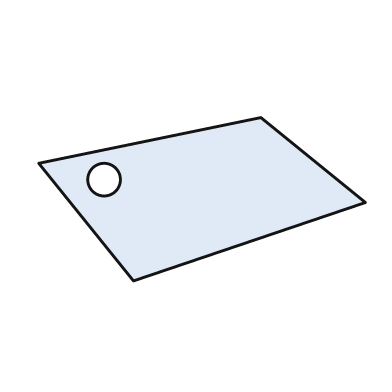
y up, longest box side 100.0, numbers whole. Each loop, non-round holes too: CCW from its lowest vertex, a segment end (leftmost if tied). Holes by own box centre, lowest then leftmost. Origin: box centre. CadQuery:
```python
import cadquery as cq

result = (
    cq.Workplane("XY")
    .moveTo(-21.0, -25.0)
    .lineTo(50.0, -1.0)
    .lineTo(18.0, 25.0)
    .lineTo(-50.0, 11.0)
    .close()
    .moveTo(-30.0, 6.0)
    .circle(5.0)
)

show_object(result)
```